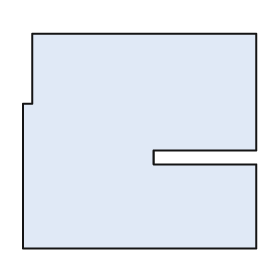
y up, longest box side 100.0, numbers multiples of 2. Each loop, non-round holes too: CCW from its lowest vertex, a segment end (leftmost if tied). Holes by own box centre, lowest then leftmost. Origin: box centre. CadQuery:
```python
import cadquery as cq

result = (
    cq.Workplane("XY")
    .moveTo(-50.0, -46.0)
    .lineTo(50.0, -46.0)
    .lineTo(50.0, -10.0)
    .lineTo(6.0, -10.0)
    .lineTo(6.0, -4.0)
    .lineTo(50.0, -4.0)
    .lineTo(50.0, 46.0)
    .lineTo(-46.0, 46.0)
    .lineTo(-46.0, 16.0)
    .lineTo(-50.0, 16.0)
    .close()
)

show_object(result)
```